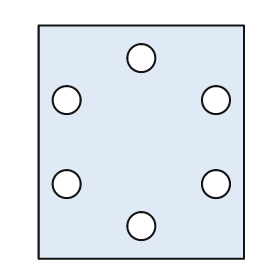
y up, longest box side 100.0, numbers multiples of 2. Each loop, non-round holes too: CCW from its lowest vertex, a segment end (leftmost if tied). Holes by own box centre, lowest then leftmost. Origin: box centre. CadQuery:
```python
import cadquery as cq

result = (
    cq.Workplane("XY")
    .moveTo(-44.0, -50.0)
    .lineTo(44.0, -50.0)
    .lineTo(44.0, 50.0)
    .lineTo(-44.0, 50.0)
    .close()
    .moveTo(0.0, -36.0)
    .circle(6.0)
    .moveTo(-32.0, -18.0)
    .circle(6.0)
    .moveTo(32.0, -18.0)
    .circle(6.0)
    .moveTo(-32.0, 18.0)
    .circle(6.0)
    .moveTo(32.0, 18.0)
    .circle(6.0)
    .moveTo(0.0, 36.0)
    .circle(6.0)
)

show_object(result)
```